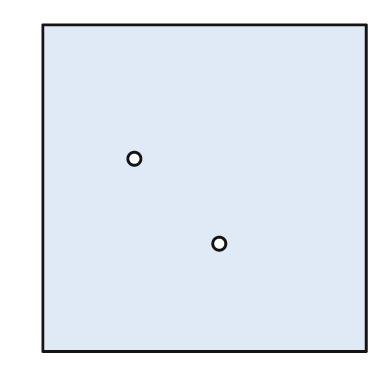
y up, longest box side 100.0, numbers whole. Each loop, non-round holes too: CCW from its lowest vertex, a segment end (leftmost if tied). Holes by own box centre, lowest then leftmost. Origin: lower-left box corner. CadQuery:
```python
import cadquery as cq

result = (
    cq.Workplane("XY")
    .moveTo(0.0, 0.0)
    .lineTo(99.0, 0.0)
    .lineTo(99.0, 100.0)
    .lineTo(0.0, 100.0)
    .close()
    .moveTo(54.0, 33.0)
    .circle(2.0)
    .moveTo(28.0, 59.0)
    .circle(2.0)
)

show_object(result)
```